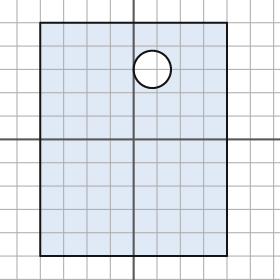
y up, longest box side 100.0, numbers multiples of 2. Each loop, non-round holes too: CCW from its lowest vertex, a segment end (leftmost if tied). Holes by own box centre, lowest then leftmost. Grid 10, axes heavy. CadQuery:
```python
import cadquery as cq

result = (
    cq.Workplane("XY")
    .moveTo(-40.0, -50.0)
    .lineTo(40.0, -50.0)
    .lineTo(40.0, 50.0)
    .lineTo(-40.0, 50.0)
    .close()
    .moveTo(8.0, 30.0)
    .circle(8.0)
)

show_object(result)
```